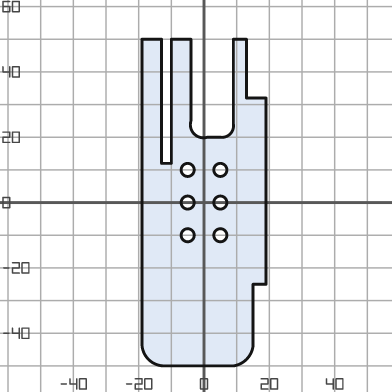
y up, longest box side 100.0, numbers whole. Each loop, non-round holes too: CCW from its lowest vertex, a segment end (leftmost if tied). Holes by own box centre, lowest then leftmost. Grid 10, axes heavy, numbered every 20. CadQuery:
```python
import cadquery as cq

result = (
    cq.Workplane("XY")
    .moveTo(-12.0, -50.0)
    .lineTo(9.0, -50.0)
    .threePointArc((13.0, -48.0), (15.0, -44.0))
    .lineTo(15.0, -25.0)
    .lineTo(19.0, -25.0)
    .lineTo(19.0, 32.0)
    .lineTo(13.0, 32.0)
    .lineTo(13.0, 50.0)
    .lineTo(9.0, 50.0)
    .lineTo(9.0, 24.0)
    .threePointArc((8.0, 21.0), (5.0, 20.0))
    .lineTo(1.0, 20.0)
    .threePointArc((-3.0, 21.0), (-4.0, 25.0))
    .lineTo(-4.0, 50.0)
    .lineTo(-10.0, 50.0)
    .lineTo(-10.0, 12.0)
    .lineTo(-13.0, 12.0)
    .lineTo(-13.0, 50.0)
    .lineTo(-19.0, 50.0)
    .lineTo(-19.0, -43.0)
    .threePointArc((-17.0, -48.0), (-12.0, -50.0))
    .close()
    .moveTo(-5.0, -10.0)
    .circle(2.0)
    .moveTo(5.0, -10.0)
    .circle(2.0)
    .moveTo(-5.0, 0.0)
    .circle(2.0)
    .moveTo(5.0, 0.0)
    .circle(2.0)
    .moveTo(-5.0, 10.0)
    .circle(2.0)
    .moveTo(5.0, 10.0)
    .circle(2.0)
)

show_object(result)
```